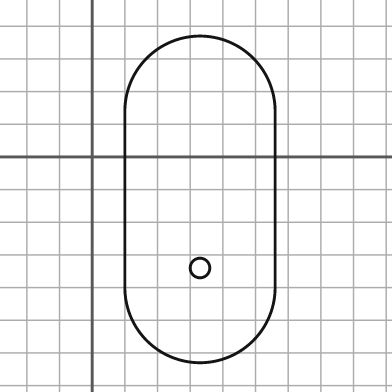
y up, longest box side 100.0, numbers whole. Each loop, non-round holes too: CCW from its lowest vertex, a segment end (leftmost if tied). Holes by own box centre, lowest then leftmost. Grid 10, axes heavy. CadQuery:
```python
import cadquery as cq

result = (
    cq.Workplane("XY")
    .moveTo(10.0, -40.0)
    .threePointArc((33.0, -63.0), (56.0, -40.0))
    .lineTo(56.0, 14.0)
    .threePointArc((33.0, 37.0), (10.0, 14.0))
    .close()
    .moveTo(33.0, -34.0)
    .circle(3.0)
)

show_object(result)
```